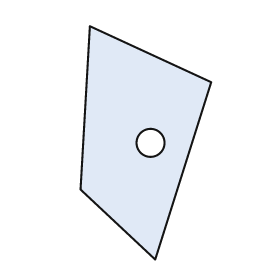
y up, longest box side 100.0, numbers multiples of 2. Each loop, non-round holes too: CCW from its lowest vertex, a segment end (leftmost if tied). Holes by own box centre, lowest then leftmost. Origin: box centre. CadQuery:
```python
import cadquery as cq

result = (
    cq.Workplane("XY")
    .moveTo(4.0, -50.0)
    .lineTo(28.0, 26.0)
    .lineTo(-24.0, 50.0)
    .lineTo(-28.0, -20.0)
    .close()
    .moveTo(2.0, 0.0)
    .circle(6.0)
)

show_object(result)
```